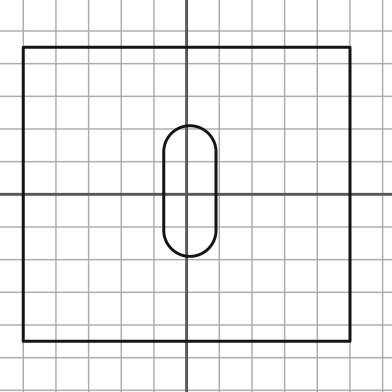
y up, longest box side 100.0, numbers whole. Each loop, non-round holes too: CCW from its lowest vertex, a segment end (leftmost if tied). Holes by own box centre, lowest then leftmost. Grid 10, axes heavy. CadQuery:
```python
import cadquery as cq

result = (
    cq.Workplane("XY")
    .moveTo(-50.0, -45.0)
    .lineTo(50.0, -45.0)
    .lineTo(50.0, 45.0)
    .lineTo(-50.0, 45.0)
    .close()
    .moveTo(-7.0, -11.0)
    .threePointArc((1.0, -19.0), (9.0, -11.0))
    .lineTo(9.0, 13.0)
    .threePointArc((1.0, 21.0), (-7.0, 13.0))
    .close()
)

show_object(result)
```